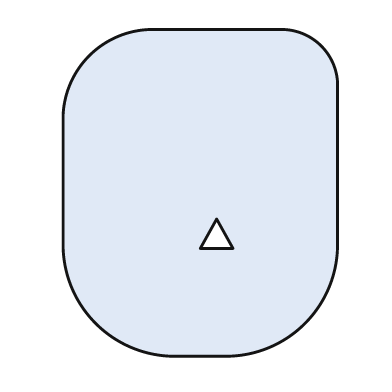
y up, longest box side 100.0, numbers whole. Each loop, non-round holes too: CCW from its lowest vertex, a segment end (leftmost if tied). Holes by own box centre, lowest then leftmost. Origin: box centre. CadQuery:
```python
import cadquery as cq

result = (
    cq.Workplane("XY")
    .moveTo(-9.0, -50.0)
    .lineTo(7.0, -50.0)
    .threePointArc((32.0, -40.0), (42.0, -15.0))
    .lineTo(42.0, 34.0)
    .threePointArc((37.0, 45.0), (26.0, 50.0))
    .lineTo(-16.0, 50.0)
    .threePointArc((-34.0, 42.0), (-42.0, 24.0))
    .lineTo(-42.0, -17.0)
    .threePointArc((-32.0, -40.0), (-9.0, -50.0))
    .close()
    .moveTo(0.0, -17.0)
    .lineTo(10.0, -17.0)
    .lineTo(5.0, -8.0)
    .close()
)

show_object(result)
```